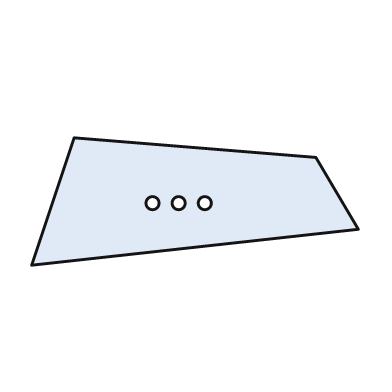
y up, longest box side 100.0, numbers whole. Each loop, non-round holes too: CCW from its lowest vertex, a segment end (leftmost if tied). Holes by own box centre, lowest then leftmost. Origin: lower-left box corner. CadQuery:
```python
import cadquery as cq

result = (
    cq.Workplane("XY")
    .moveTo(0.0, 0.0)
    .lineTo(100.0, 11.0)
    .lineTo(87.0, 33.0)
    .lineTo(13.0, 39.0)
    .close()
    .moveTo(37.0, 19.0)
    .circle(2.0)
    .moveTo(45.0, 19.0)
    .circle(2.0)
    .moveTo(53.0, 19.0)
    .circle(2.0)
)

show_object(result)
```